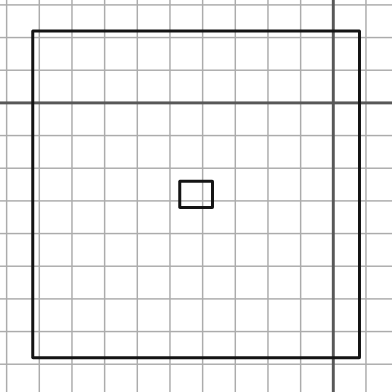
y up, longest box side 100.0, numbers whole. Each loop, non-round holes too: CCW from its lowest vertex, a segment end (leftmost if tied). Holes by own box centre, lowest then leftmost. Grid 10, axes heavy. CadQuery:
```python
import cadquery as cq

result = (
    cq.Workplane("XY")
    .moveTo(-92.0, -78.0)
    .lineTo(8.0, -78.0)
    .lineTo(8.0, 22.0)
    .lineTo(-92.0, 22.0)
    .close()
    .moveTo(-47.0, -32.0)
    .lineTo(-37.0, -32.0)
    .lineTo(-37.0, -24.0)
    .lineTo(-47.0, -24.0)
    .close()
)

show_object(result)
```